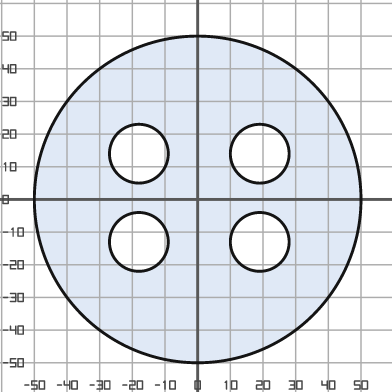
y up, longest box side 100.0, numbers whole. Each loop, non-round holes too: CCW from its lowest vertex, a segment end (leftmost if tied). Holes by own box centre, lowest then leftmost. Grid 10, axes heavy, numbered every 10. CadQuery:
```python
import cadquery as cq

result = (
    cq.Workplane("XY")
    .moveTo(0.0, 0.0)
    .circle(50.0)
    .moveTo(-18.0, -13.0)
    .circle(9.0)
    .moveTo(19.0, -13.0)
    .circle(9.0)
    .moveTo(-18.0, 14.0)
    .circle(9.0)
    .moveTo(19.0, 14.0)
    .circle(9.0)
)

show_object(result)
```